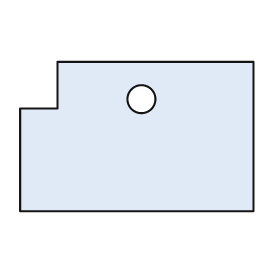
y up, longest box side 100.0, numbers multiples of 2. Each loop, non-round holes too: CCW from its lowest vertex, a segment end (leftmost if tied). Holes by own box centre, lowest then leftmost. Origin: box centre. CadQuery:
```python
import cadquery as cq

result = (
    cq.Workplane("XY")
    .moveTo(-50.0, -32.0)
    .lineTo(50.0, -32.0)
    .lineTo(50.0, 32.0)
    .lineTo(-34.0, 32.0)
    .lineTo(-34.0, 12.0)
    .lineTo(-50.0, 12.0)
    .close()
    .moveTo(2.0, 16.0)
    .circle(6.0)
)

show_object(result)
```